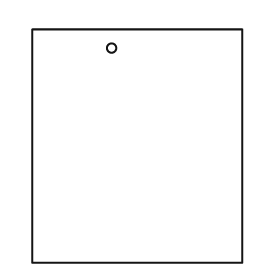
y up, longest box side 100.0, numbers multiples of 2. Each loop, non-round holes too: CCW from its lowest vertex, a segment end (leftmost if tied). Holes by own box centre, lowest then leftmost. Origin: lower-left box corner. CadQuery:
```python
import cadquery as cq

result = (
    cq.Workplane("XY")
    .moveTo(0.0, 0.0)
    .lineTo(90.0, 0.0)
    .lineTo(90.0, 100.0)
    .lineTo(0.0, 100.0)
    .close()
    .moveTo(34.0, 92.0)
    .circle(2.0)
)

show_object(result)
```